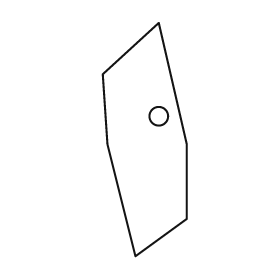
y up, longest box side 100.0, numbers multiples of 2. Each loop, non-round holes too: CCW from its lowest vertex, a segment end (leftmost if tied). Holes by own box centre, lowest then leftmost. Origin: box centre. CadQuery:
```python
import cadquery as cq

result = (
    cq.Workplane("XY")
    .moveTo(-4.0, -50.0)
    .lineTo(18.0, -34.0)
    .lineTo(18.0, -2.0)
    .lineTo(6.0, 50.0)
    .lineTo(-18.0, 28.0)
    .lineTo(-16.0, -2.0)
    .close()
    .moveTo(6.0, 10.0)
    .circle(4.0)
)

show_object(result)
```